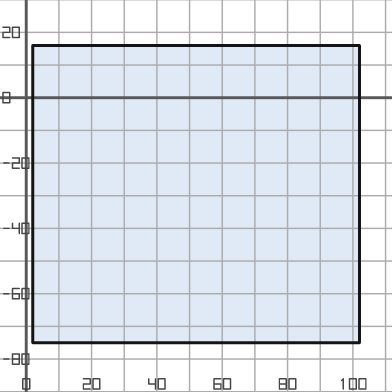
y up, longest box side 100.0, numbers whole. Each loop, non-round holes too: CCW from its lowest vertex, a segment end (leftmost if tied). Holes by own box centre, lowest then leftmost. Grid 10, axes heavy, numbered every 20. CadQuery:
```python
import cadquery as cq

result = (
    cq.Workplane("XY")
    .moveTo(2.0, -75.0)
    .lineTo(102.0, -75.0)
    .lineTo(102.0, 16.0)
    .lineTo(2.0, 16.0)
    .close()
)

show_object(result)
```